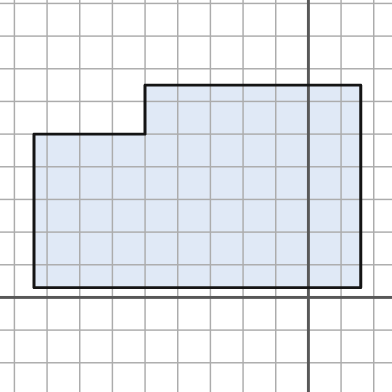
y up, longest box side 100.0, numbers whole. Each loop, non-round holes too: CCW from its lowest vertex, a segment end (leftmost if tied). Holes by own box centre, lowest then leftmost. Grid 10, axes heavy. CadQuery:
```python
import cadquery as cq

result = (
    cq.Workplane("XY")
    .moveTo(-84.0, 3.0)
    .lineTo(16.0, 3.0)
    .lineTo(16.0, 65.0)
    .lineTo(-50.0, 65.0)
    .lineTo(-50.0, 50.0)
    .lineTo(-84.0, 50.0)
    .close()
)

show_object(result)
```